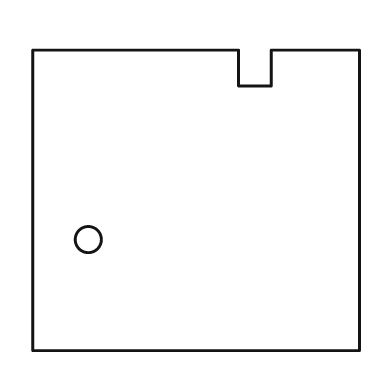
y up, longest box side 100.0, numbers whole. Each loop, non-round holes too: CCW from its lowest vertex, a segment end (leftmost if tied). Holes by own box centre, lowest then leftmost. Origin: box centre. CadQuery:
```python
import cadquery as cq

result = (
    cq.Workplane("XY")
    .moveTo(-50.0, -46.0)
    .lineTo(50.0, -46.0)
    .lineTo(50.0, 46.0)
    .lineTo(23.0, 46.0)
    .lineTo(23.0, 35.0)
    .lineTo(13.0, 35.0)
    .lineTo(13.0, 46.0)
    .lineTo(-50.0, 46.0)
    .close()
    .moveTo(-33.0, -12.0)
    .circle(4.0)
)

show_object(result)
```